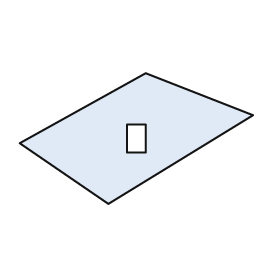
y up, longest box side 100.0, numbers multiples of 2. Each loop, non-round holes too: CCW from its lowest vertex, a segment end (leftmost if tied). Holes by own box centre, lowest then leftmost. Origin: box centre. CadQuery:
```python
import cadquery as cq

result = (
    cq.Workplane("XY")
    .moveTo(-12.0, -28.0)
    .lineTo(50.0, 10.0)
    .lineTo(4.0, 28.0)
    .lineTo(-50.0, -2.0)
    .close()
    .moveTo(-4.0, -6.0)
    .lineTo(4.0, -6.0)
    .lineTo(4.0, 6.0)
    .lineTo(-4.0, 6.0)
    .close()
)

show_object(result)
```